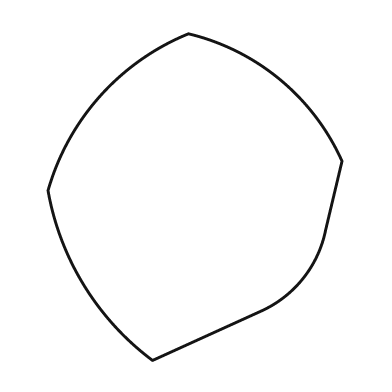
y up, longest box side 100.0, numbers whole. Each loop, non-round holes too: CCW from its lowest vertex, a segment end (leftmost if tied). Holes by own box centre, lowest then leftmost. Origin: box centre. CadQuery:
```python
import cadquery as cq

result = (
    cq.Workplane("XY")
    .moveTo(-13.0, -50.0)
    .lineTo(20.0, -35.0)
    .threePointArc((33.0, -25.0), (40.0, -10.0))
    .lineTo(45.0, 11.0)
    .threePointArc((26.0, 36.0), (-2.0, 50.0))
    .threePointArc((-29.0, 31.0), (-45.0, 2.0))
    .threePointArc((-34.0, -27.0), (-13.0, -50.0))
    .close()
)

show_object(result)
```